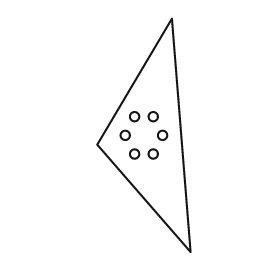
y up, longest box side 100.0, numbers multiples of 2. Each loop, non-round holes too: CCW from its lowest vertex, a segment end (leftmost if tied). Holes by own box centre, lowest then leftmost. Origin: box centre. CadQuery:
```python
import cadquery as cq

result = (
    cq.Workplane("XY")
    .moveTo(20.0, -50.0)
    .lineTo(12.0, 50.0)
    .lineTo(-20.0, -4.0)
    .close()
    .moveTo(-4.0, -8.0)
    .circle(2.0)
    .moveTo(4.0, -8.0)
    .circle(2.0)
    .moveTo(-8.0, 0.0)
    .circle(2.0)
    .moveTo(8.0, 0.0)
    .circle(2.0)
    .moveTo(-4.0, 8.0)
    .circle(2.0)
    .moveTo(4.0, 8.0)
    .circle(2.0)
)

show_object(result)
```